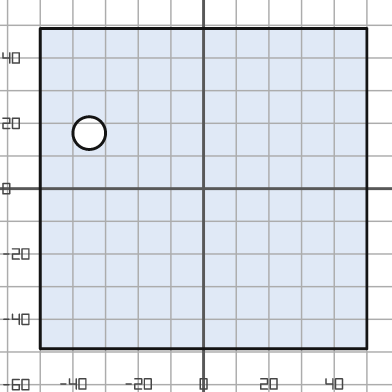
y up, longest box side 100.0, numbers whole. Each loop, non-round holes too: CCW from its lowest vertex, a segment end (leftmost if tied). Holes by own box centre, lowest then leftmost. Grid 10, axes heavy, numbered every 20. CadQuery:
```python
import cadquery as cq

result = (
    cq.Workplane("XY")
    .moveTo(-50.0, -49.0)
    .lineTo(50.0, -49.0)
    .lineTo(50.0, 49.0)
    .lineTo(-50.0, 49.0)
    .close()
    .moveTo(-35.0, 17.0)
    .circle(5.0)
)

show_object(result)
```